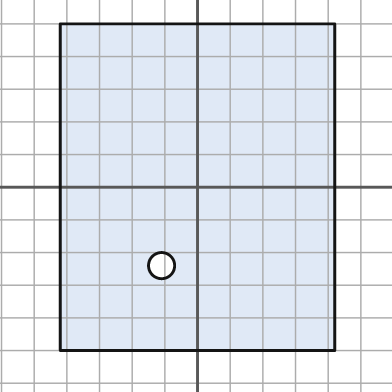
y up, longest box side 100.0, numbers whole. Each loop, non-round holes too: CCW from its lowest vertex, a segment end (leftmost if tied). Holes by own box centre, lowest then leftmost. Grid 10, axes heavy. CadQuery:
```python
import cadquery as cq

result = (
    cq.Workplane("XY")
    .moveTo(-42.0, -50.0)
    .lineTo(42.0, -50.0)
    .lineTo(42.0, 50.0)
    .lineTo(-42.0, 50.0)
    .close()
    .moveTo(-11.0, -24.0)
    .circle(4.0)
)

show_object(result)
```